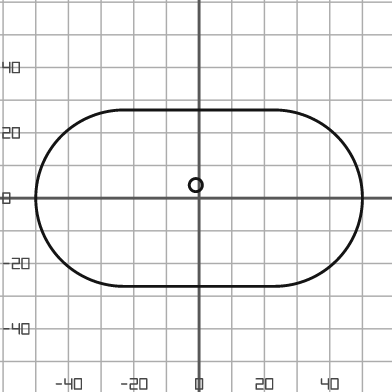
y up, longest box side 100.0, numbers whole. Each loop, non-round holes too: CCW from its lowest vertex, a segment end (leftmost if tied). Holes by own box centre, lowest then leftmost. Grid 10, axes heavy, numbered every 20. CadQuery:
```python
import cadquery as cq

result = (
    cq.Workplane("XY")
    .moveTo(-23.0, -27.0)
    .lineTo(23.0, -27.0)
    .threePointArc((50.0, 0.0), (23.0, 27.0))
    .lineTo(-23.0, 27.0)
    .threePointArc((-50.0, 0.0), (-23.0, -27.0))
    .close()
    .moveTo(-1.0, 4.0)
    .circle(2.0)
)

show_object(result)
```